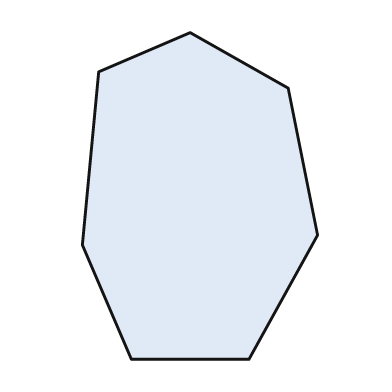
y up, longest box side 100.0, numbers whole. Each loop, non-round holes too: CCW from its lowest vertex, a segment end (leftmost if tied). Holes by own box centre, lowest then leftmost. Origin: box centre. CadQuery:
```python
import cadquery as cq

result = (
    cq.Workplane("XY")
    .moveTo(-21.0, -50.0)
    .lineTo(15.0, -50.0)
    .lineTo(36.0, -12.0)
    .lineTo(27.0, 33.0)
    .lineTo(-3.0, 50.0)
    .lineTo(-31.0, 38.0)
    .lineTo(-36.0, -15.0)
    .close()
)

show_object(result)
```